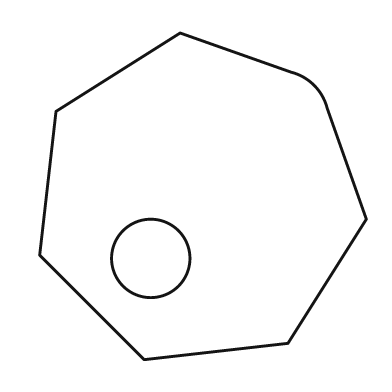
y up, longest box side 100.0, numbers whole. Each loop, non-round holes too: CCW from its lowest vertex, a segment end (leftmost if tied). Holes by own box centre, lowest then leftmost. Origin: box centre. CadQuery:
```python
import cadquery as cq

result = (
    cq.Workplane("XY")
    .moveTo(-18.0, -50.0)
    .lineTo(26.0, -45.0)
    .lineTo(50.0, -7.0)
    .lineTo(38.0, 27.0)
    .threePointArc((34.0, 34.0), (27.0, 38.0))
    .lineTo(-7.0, 50.0)
    .lineTo(-45.0, 26.0)
    .lineTo(-50.0, -18.0)
    .close()
    .moveTo(-16.0, -19.0)
    .circle(12.0)
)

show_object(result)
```